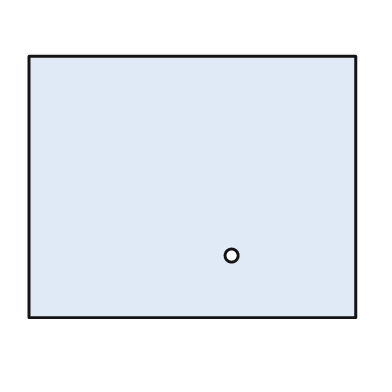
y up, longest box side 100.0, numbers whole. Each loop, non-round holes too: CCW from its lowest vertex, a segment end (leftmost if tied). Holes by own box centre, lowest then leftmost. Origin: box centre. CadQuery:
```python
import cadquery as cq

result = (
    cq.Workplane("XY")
    .moveTo(-50.0, -40.0)
    .lineTo(50.0, -40.0)
    .lineTo(50.0, 40.0)
    .lineTo(-50.0, 40.0)
    .close()
    .moveTo(12.0, -21.0)
    .circle(2.0)
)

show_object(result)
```